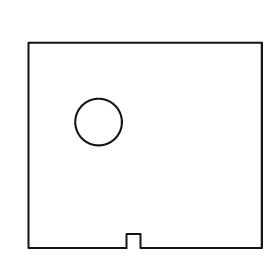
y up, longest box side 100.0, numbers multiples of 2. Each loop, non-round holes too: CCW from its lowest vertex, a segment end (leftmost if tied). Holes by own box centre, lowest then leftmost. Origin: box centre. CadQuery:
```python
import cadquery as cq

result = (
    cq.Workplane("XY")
    .moveTo(-50.0, -44.0)
    .lineTo(-8.0, -44.0)
    .lineTo(-8.0, -38.0)
    .lineTo(-2.0, -38.0)
    .lineTo(-2.0, -44.0)
    .lineTo(50.0, -44.0)
    .lineTo(50.0, 44.0)
    .lineTo(-50.0, 44.0)
    .close()
    .moveTo(-20.0, 10.0)
    .circle(10.0)
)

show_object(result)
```